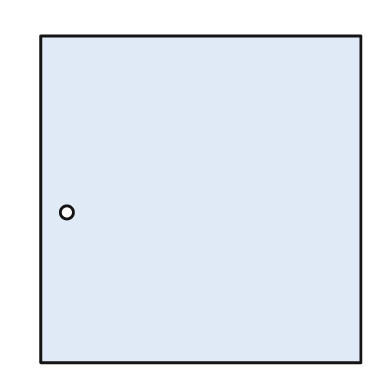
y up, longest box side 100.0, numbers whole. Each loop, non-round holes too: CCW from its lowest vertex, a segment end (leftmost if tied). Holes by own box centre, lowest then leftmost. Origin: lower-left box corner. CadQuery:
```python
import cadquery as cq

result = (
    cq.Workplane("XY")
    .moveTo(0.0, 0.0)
    .lineTo(98.0, 0.0)
    .lineTo(98.0, 100.0)
    .lineTo(0.0, 100.0)
    .close()
    .moveTo(8.0, 46.0)
    .circle(2.0)
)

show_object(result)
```